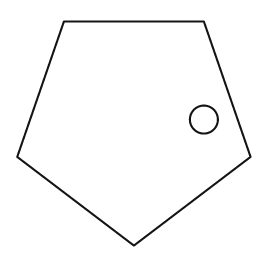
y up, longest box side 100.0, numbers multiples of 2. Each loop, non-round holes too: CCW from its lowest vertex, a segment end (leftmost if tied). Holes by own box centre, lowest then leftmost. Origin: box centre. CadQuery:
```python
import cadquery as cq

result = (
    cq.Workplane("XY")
    .moveTo(0.0, -48.0)
    .lineTo(50.0, -10.0)
    .lineTo(30.0, 48.0)
    .lineTo(-30.0, 48.0)
    .lineTo(-50.0, -10.0)
    .close()
    .moveTo(30.0, 6.0)
    .circle(6.0)
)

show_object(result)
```